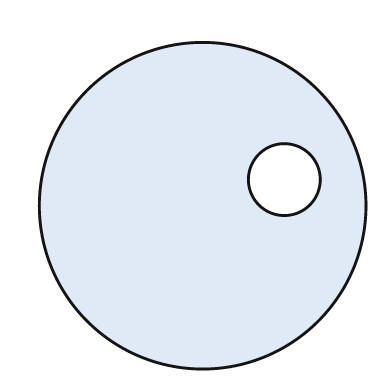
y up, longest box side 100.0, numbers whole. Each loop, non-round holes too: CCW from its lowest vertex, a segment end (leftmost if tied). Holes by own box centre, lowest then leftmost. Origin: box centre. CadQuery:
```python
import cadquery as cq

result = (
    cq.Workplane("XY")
    .moveTo(0.0, 0.0)
    .circle(50.0)
    .moveTo(25.0, 8.0)
    .circle(11.0)
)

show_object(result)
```